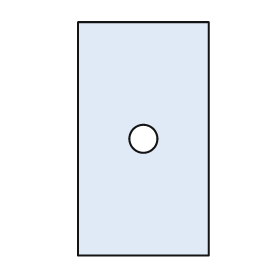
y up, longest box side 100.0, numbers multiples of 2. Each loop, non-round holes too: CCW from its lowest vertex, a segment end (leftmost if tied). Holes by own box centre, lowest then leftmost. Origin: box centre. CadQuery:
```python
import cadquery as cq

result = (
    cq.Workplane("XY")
    .moveTo(-28.0, -50.0)
    .lineTo(28.0, -50.0)
    .lineTo(28.0, 50.0)
    .lineTo(-28.0, 50.0)
    .close()
    .moveTo(0.0, 0.0)
    .circle(6.0)
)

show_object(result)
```